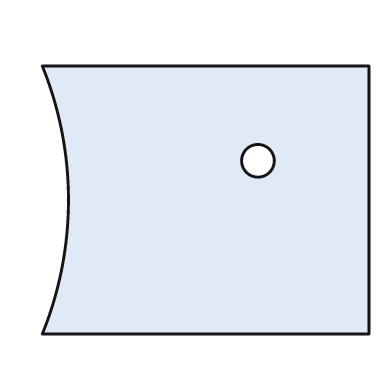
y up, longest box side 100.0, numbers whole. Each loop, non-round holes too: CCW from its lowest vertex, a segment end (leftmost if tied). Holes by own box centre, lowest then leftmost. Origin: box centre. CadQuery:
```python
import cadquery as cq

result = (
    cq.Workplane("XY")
    .moveTo(-50.0, -41.0)
    .lineTo(50.0, -41.0)
    .lineTo(50.0, 41.0)
    .lineTo(-50.0, 41.0)
    .threePointArc((-42.0, 0.0), (-50.0, -41.0))
    .close()
    .moveTo(16.0, 12.0)
    .circle(5.0)
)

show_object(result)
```